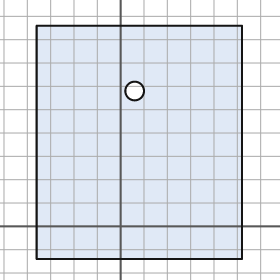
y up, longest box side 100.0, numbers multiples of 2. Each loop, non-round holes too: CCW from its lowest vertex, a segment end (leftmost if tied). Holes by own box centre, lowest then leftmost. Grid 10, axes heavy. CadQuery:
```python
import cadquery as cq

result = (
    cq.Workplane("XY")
    .moveTo(-36.0, -14.0)
    .lineTo(52.0, -14.0)
    .lineTo(52.0, 86.0)
    .lineTo(-36.0, 86.0)
    .close()
    .moveTo(6.0, 58.0)
    .circle(4.0)
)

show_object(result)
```